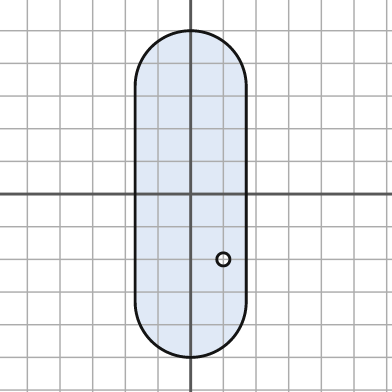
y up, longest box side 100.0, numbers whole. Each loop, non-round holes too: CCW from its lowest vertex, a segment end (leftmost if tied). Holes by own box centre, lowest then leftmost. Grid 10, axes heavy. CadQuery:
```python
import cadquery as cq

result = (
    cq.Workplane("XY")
    .moveTo(-17.0, -33.0)
    .threePointArc((0.0, -50.0), (17.0, -33.0))
    .lineTo(17.0, 33.0)
    .threePointArc((0.0, 50.0), (-17.0, 33.0))
    .close()
    .moveTo(10.0, -20.0)
    .circle(2.0)
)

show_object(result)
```